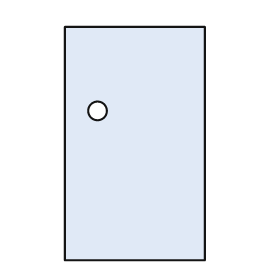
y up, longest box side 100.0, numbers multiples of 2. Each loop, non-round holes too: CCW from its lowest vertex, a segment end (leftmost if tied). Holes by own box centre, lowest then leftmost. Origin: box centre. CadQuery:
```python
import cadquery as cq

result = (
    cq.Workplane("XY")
    .moveTo(-30.0, -50.0)
    .lineTo(30.0, -50.0)
    .lineTo(30.0, 50.0)
    .lineTo(-30.0, 50.0)
    .close()
    .moveTo(-16.0, 14.0)
    .circle(4.0)
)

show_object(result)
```